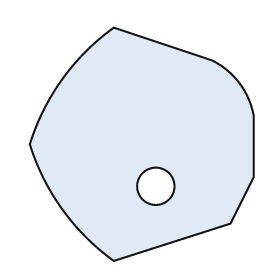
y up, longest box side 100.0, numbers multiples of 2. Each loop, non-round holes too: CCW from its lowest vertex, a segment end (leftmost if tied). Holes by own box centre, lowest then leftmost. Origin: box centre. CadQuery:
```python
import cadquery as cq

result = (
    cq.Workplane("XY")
    .moveTo(-12.0, -50.0)
    .lineTo(38.0, -34.0)
    .lineTo(48.0, -14.0)
    .lineTo(48.0, 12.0)
    .threePointArc((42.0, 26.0), (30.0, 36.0))
    .lineTo(-12.0, 50.0)
    .threePointArc((-34.0, 28.0), (-48.0, 0.0))
    .threePointArc((-34.0, -28.0), (-12.0, -50.0))
    .close()
    .moveTo(6.0, -18.0)
    .circle(8.0)
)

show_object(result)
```